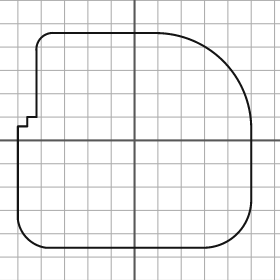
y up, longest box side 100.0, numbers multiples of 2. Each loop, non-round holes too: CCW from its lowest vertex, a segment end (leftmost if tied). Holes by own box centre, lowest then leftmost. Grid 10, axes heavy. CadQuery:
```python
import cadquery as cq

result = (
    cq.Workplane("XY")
    .moveTo(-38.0, -46.0)
    .lineTo(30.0, -46.0)
    .threePointArc((44.0, -40.0), (50.0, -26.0))
    .lineTo(50.0, 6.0)
    .threePointArc((38.0, 34.0), (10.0, 46.0))
    .lineTo(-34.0, 46.0)
    .threePointArc((-40.0, 44.0), (-42.0, 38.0))
    .lineTo(-42.0, 10.0)
    .lineTo(-46.0, 10.0)
    .lineTo(-46.0, 6.0)
    .lineTo(-50.0, 6.0)
    .lineTo(-50.0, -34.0)
    .threePointArc((-46.0, -42.0), (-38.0, -46.0))
    .close()
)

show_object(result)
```